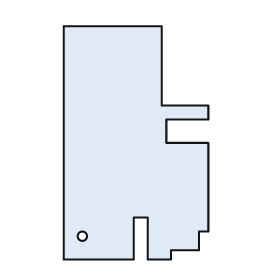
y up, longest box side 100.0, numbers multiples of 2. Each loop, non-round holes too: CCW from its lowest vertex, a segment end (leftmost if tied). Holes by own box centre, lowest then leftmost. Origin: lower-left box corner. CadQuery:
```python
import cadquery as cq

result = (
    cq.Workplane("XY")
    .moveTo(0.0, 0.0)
    .lineTo(30.0, 0.0)
    .lineTo(30.0, 18.0)
    .lineTo(36.0, 18.0)
    .lineTo(36.0, 0.0)
    .lineTo(46.0, 0.0)
    .lineTo(46.0, 4.0)
    .lineTo(58.0, 4.0)
    .lineTo(58.0, 12.0)
    .lineTo(62.0, 12.0)
    .lineTo(62.0, 50.0)
    .lineTo(44.0, 50.0)
    .lineTo(44.0, 60.0)
    .lineTo(62.0, 60.0)
    .lineTo(62.0, 66.0)
    .lineTo(42.0, 66.0)
    .lineTo(42.0, 100.0)
    .lineTo(0.0, 100.0)
    .close()
    .moveTo(8.0, 10.0)
    .circle(2.0)
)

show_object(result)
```